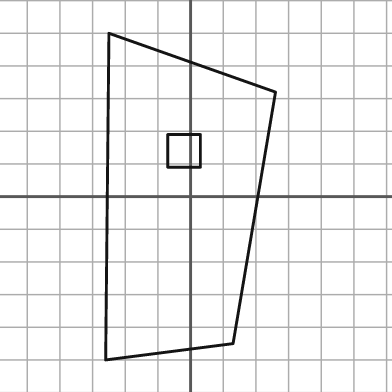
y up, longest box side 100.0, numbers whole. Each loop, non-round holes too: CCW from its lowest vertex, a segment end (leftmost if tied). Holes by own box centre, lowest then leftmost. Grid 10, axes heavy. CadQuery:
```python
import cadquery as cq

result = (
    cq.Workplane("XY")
    .moveTo(-26.0, -50.0)
    .lineTo(13.0, -45.0)
    .lineTo(26.0, 32.0)
    .lineTo(-25.0, 50.0)
    .close()
    .moveTo(-7.0, 9.0)
    .lineTo(3.0, 9.0)
    .lineTo(3.0, 19.0)
    .lineTo(-7.0, 19.0)
    .close()
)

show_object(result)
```